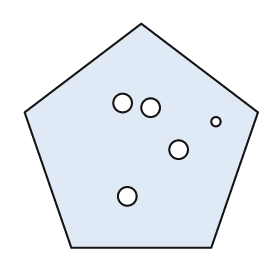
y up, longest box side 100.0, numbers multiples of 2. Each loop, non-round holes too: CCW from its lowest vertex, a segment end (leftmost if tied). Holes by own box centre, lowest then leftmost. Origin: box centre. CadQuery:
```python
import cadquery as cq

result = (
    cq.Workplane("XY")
    .moveTo(-30.0, -48.0)
    .lineTo(30.0, -48.0)
    .lineTo(50.0, 10.0)
    .lineTo(0.0, 48.0)
    .lineTo(-50.0, 10.0)
    .close()
    .moveTo(-6.0, -26.0)
    .circle(4.0)
    .moveTo(16.0, -6.0)
    .circle(4.0)
    .moveTo(32.0, 6.0)
    .circle(2.0)
    .moveTo(4.0, 12.0)
    .circle(4.0)
    .moveTo(-8.0, 14.0)
    .circle(4.0)
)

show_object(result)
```